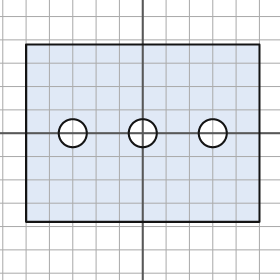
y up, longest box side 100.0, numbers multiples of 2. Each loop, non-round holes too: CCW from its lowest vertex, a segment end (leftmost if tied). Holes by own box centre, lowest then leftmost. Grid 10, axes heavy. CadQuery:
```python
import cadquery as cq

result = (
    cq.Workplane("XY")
    .moveTo(-50.0, -38.0)
    .lineTo(50.0, -38.0)
    .lineTo(50.0, 38.0)
    .lineTo(-50.0, 38.0)
    .close()
    .moveTo(-30.0, 0.0)
    .circle(6.0)
    .moveTo(0.0, 0.0)
    .circle(6.0)
    .moveTo(30.0, 0.0)
    .circle(6.0)
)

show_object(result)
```